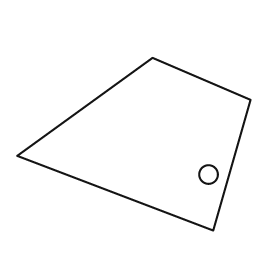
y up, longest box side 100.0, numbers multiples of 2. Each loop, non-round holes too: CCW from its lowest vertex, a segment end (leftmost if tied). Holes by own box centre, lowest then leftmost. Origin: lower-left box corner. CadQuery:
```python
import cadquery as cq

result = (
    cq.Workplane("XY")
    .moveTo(84.0, 0.0)
    .lineTo(100.0, 56.0)
    .lineTo(58.0, 74.0)
    .lineTo(0.0, 32.0)
    .close()
    .moveTo(82.0, 24.0)
    .circle(4.0)
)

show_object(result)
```